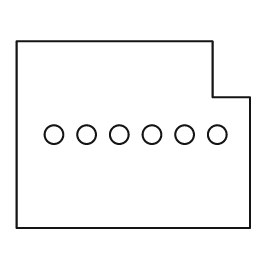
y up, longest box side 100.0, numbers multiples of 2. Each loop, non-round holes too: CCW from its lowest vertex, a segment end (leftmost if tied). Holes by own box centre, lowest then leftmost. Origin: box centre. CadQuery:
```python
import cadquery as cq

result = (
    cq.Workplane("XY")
    .moveTo(-50.0, -40.0)
    .lineTo(50.0, -40.0)
    .lineTo(50.0, 16.0)
    .lineTo(34.0, 16.0)
    .lineTo(34.0, 40.0)
    .lineTo(-50.0, 40.0)
    .close()
    .moveTo(-34.0, 0.0)
    .circle(4.0)
    .moveTo(-20.0, 0.0)
    .circle(4.0)
    .moveTo(-6.0, 0.0)
    .circle(4.0)
    .moveTo(8.0, 0.0)
    .circle(4.0)
    .moveTo(22.0, 0.0)
    .circle(4.0)
    .moveTo(36.0, 0.0)
    .circle(4.0)
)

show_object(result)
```